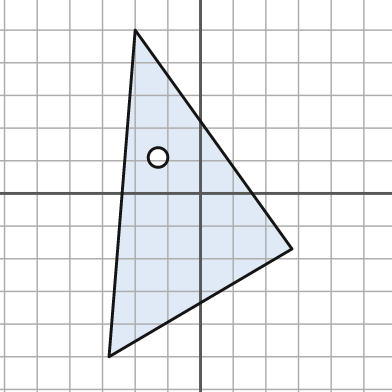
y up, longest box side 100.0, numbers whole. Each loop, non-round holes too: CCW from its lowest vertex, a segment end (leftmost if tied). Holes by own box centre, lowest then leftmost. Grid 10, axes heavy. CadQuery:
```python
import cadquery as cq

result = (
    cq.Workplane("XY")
    .moveTo(-28.0, -50.0)
    .lineTo(28.0, -17.0)
    .lineTo(-20.0, 50.0)
    .close()
    .moveTo(-13.0, 11.0)
    .circle(3.0)
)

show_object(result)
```